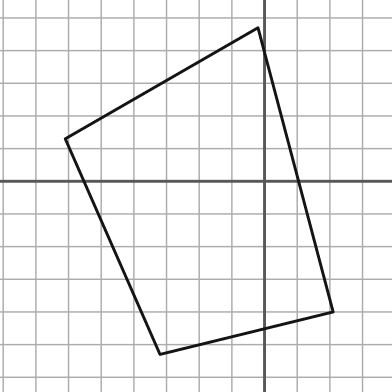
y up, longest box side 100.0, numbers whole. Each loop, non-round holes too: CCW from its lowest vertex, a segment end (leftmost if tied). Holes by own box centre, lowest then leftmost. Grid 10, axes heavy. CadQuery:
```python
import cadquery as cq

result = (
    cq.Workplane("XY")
    .moveTo(-32.0, -53.0)
    .lineTo(21.0, -40.0)
    .lineTo(-2.0, 47.0)
    .lineTo(-61.0, 13.0)
    .close()
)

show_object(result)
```